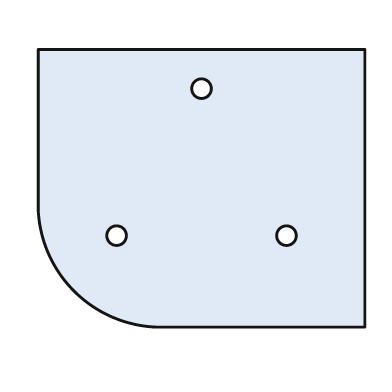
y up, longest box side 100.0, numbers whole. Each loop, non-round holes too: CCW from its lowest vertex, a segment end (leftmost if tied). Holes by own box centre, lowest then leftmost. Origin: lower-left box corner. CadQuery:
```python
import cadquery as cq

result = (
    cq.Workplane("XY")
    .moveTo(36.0, 0.0)
    .lineTo(100.0, 0.0)
    .lineTo(100.0, 85.0)
    .lineTo(0.0, 85.0)
    .lineTo(0.0, 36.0)
    .threePointArc((11.0, 11.0), (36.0, 0.0))
    .close()
    .moveTo(24.0, 28.0)
    .circle(3.0)
    .moveTo(76.0, 28.0)
    .circle(3.0)
    .moveTo(50.0, 73.0)
    .circle(3.0)
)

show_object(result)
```